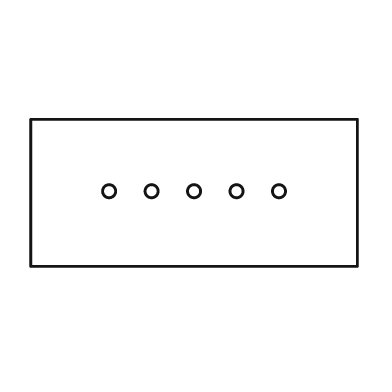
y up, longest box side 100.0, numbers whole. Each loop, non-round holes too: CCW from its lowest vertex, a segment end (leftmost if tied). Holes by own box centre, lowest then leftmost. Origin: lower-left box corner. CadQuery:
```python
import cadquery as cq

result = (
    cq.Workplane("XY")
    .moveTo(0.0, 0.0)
    .lineTo(100.0, 0.0)
    .lineTo(100.0, 45.0)
    .lineTo(0.0, 45.0)
    .close()
    .moveTo(24.0, 23.0)
    .circle(2.0)
    .moveTo(37.0, 23.0)
    .circle(2.0)
    .moveTo(50.0, 23.0)
    .circle(2.0)
    .moveTo(63.0, 23.0)
    .circle(2.0)
    .moveTo(76.0, 23.0)
    .circle(2.0)
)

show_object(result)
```